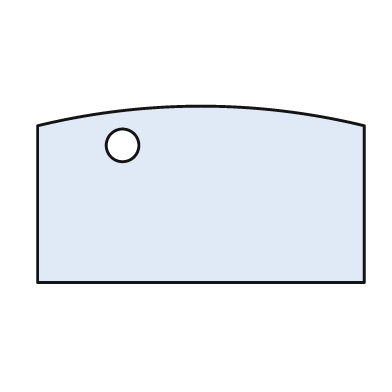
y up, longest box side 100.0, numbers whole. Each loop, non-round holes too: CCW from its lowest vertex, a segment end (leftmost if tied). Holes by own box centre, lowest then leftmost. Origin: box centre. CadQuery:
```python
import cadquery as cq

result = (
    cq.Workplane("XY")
    .moveTo(-50.0, -27.0)
    .lineTo(50.0, -27.0)
    .lineTo(50.0, 21.0)
    .threePointArc((0.0, 27.0), (-50.0, 21.0))
    .close()
    .moveTo(-24.0, 15.0)
    .circle(5.0)
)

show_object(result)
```